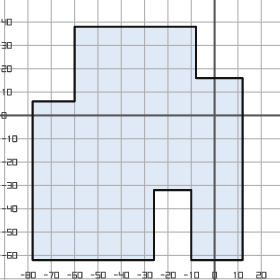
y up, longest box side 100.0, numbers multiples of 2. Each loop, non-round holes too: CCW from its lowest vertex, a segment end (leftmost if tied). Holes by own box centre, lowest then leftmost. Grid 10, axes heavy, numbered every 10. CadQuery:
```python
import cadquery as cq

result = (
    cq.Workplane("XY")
    .moveTo(-78.0, -62.0)
    .lineTo(-26.0, -62.0)
    .lineTo(-26.0, -32.0)
    .lineTo(-10.0, -32.0)
    .lineTo(-10.0, -62.0)
    .lineTo(12.0, -62.0)
    .lineTo(12.0, 16.0)
    .lineTo(-8.0, 16.0)
    .lineTo(-8.0, 38.0)
    .lineTo(-60.0, 38.0)
    .lineTo(-60.0, 6.0)
    .lineTo(-78.0, 6.0)
    .close()
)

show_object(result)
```